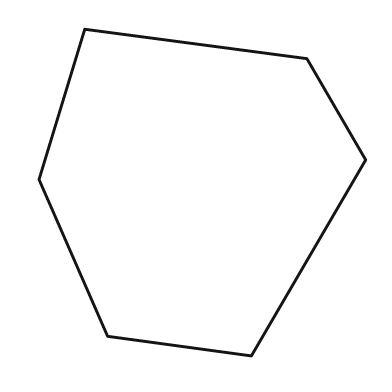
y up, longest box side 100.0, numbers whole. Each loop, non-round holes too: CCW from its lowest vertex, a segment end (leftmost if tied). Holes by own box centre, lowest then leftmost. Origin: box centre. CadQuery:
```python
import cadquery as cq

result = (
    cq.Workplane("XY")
    .moveTo(15.0, -50.0)
    .lineTo(50.0, 10.0)
    .lineTo(32.0, 41.0)
    .lineTo(-36.0, 50.0)
    .lineTo(-50.0, 4.0)
    .lineTo(-29.0, -44.0)
    .close()
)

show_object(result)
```